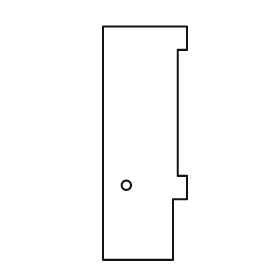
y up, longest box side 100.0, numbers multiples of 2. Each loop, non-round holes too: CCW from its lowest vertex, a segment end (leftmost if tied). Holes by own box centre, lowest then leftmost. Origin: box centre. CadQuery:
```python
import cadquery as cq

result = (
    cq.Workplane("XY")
    .moveTo(-18.0, -50.0)
    .lineTo(12.0, -50.0)
    .lineTo(12.0, -24.0)
    .lineTo(18.0, -24.0)
    .lineTo(18.0, -14.0)
    .lineTo(14.0, -14.0)
    .lineTo(14.0, 40.0)
    .lineTo(18.0, 40.0)
    .lineTo(18.0, 50.0)
    .lineTo(-18.0, 50.0)
    .close()
    .moveTo(-8.0, -18.0)
    .circle(2.0)
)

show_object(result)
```